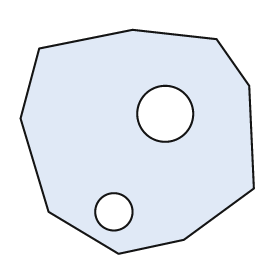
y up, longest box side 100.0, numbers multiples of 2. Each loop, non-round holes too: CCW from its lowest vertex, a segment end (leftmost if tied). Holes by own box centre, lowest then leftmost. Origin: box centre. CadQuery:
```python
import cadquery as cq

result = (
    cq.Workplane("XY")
    .moveTo(-8.0, -48.0)
    .lineTo(20.0, -42.0)
    .lineTo(50.0, -20.0)
    .lineTo(48.0, 24.0)
    .lineTo(34.0, 44.0)
    .lineTo(-2.0, 48.0)
    .lineTo(-42.0, 40.0)
    .lineTo(-50.0, 10.0)
    .lineTo(-38.0, -30.0)
    .close()
    .moveTo(-10.0, -30.0)
    .circle(8.0)
    .moveTo(12.0, 12.0)
    .circle(12.0)
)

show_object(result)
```